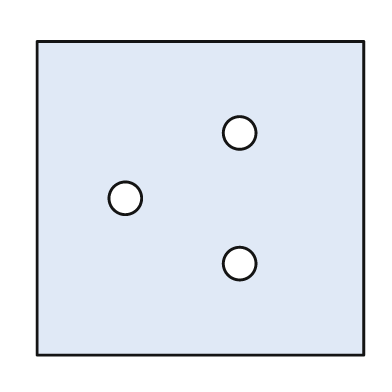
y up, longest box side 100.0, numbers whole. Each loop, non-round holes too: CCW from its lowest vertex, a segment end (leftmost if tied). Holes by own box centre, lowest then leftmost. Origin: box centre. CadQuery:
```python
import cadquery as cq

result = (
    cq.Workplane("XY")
    .moveTo(-50.0, -48.0)
    .lineTo(50.0, -48.0)
    .lineTo(50.0, 48.0)
    .lineTo(-50.0, 48.0)
    .close()
    .moveTo(12.0, -20.0)
    .circle(5.0)
    .moveTo(-23.0, 0.0)
    .circle(5.0)
    .moveTo(12.0, 20.0)
    .circle(5.0)
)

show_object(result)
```